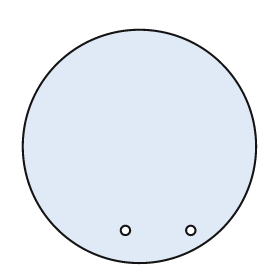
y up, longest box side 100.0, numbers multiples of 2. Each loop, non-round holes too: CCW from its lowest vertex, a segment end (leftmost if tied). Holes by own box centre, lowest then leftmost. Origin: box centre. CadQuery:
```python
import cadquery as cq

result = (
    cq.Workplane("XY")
    .moveTo(0.0, 0.0)
    .circle(50.0)
    .moveTo(-6.0, -36.0)
    .circle(2.0)
    .moveTo(22.0, -36.0)
    .circle(2.0)
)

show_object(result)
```